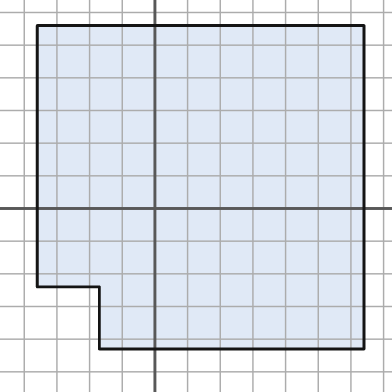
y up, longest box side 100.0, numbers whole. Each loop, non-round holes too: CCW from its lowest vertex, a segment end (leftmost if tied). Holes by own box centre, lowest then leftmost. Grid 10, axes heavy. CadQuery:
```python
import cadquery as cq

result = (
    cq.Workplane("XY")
    .moveTo(-17.0, -43.0)
    .lineTo(64.0, -43.0)
    .lineTo(64.0, 56.0)
    .lineTo(-36.0, 56.0)
    .lineTo(-36.0, -24.0)
    .lineTo(-17.0, -24.0)
    .close()
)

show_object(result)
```